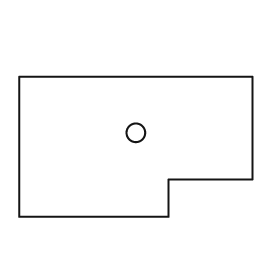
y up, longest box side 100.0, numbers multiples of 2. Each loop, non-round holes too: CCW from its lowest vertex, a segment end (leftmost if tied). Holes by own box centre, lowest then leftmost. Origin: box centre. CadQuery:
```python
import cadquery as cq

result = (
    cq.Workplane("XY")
    .moveTo(-50.0, -30.0)
    .lineTo(14.0, -30.0)
    .lineTo(14.0, -14.0)
    .lineTo(50.0, -14.0)
    .lineTo(50.0, 30.0)
    .lineTo(-50.0, 30.0)
    .close()
    .moveTo(0.0, 6.0)
    .circle(4.0)
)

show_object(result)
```